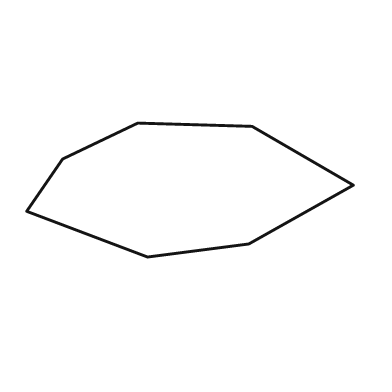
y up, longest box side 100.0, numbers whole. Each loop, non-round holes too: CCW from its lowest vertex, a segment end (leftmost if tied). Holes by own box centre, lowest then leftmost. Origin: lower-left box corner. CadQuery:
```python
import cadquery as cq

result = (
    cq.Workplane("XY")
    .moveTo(37.0, 0.0)
    .lineTo(68.0, 4.0)
    .lineTo(100.0, 22.0)
    .lineTo(69.0, 40.0)
    .lineTo(34.0, 41.0)
    .lineTo(11.0, 30.0)
    .lineTo(0.0, 14.0)
    .close()
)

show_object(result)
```